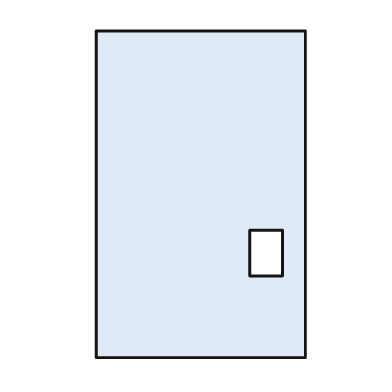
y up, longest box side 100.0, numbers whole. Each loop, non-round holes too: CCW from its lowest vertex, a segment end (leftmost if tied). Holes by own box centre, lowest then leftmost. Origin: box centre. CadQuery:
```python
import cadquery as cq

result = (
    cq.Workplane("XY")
    .moveTo(-32.0, -50.0)
    .lineTo(32.0, -50.0)
    .lineTo(32.0, 50.0)
    .lineTo(-32.0, 50.0)
    .close()
    .moveTo(15.0, -25.0)
    .lineTo(25.0, -25.0)
    .lineTo(25.0, -11.0)
    .lineTo(15.0, -11.0)
    .close()
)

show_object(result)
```